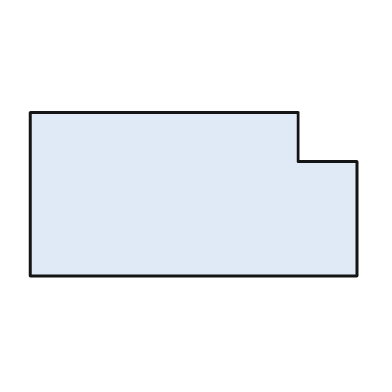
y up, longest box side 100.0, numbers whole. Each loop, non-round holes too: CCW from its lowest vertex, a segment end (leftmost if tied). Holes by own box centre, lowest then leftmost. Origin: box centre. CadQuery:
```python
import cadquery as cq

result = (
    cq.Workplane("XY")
    .moveTo(-50.0, -25.0)
    .lineTo(50.0, -25.0)
    .lineTo(50.0, 10.0)
    .lineTo(32.0, 10.0)
    .lineTo(32.0, 25.0)
    .lineTo(-50.0, 25.0)
    .close()
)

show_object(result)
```